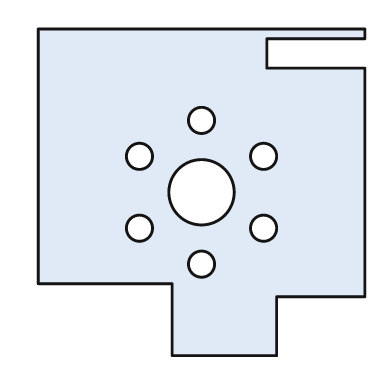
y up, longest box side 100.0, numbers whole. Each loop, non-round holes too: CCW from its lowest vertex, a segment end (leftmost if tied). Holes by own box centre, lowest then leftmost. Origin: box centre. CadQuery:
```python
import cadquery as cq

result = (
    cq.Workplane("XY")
    .moveTo(-9.0, -50.0)
    .lineTo(23.0, -50.0)
    .lineTo(23.0, -32.0)
    .lineTo(50.0, -32.0)
    .lineTo(50.0, 38.0)
    .lineTo(20.0, 38.0)
    .lineTo(20.0, 47.0)
    .lineTo(50.0, 47.0)
    .lineTo(50.0, 50.0)
    .lineTo(-50.0, 50.0)
    .lineTo(-50.0, -28.0)
    .lineTo(-9.0, -28.0)
    .close()
    .moveTo(0.0, -22.0)
    .circle(4.0)
    .moveTo(-19.0, -11.0)
    .circle(4.0)
    .moveTo(19.0, -11.0)
    .circle(4.0)
    .moveTo(0.0, 0.0)
    .circle(10.0)
    .moveTo(-19.0, 11.0)
    .circle(4.0)
    .moveTo(19.0, 11.0)
    .circle(4.0)
    .moveTo(0.0, 22.0)
    .circle(4.0)
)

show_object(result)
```